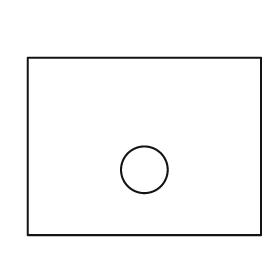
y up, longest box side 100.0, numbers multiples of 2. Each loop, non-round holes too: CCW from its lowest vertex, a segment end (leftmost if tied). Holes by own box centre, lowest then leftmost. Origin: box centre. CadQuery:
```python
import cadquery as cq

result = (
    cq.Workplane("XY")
    .moveTo(-50.0, -38.0)
    .lineTo(50.0, -38.0)
    .lineTo(50.0, 38.0)
    .lineTo(-50.0, 38.0)
    .close()
    .moveTo(0.0, -10.0)
    .circle(10.0)
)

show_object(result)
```